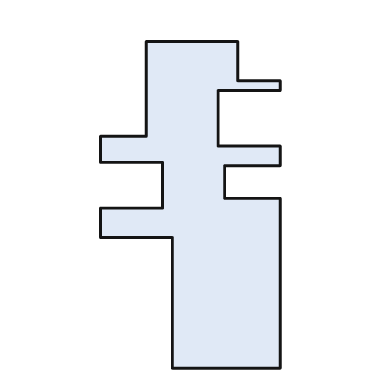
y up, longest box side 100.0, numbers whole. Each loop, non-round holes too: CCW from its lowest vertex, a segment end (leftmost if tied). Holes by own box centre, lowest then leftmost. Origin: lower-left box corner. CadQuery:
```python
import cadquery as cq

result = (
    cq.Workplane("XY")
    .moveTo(22.0, 0.0)
    .lineTo(55.0, 0.0)
    .lineTo(55.0, 52.0)
    .lineTo(38.0, 52.0)
    .lineTo(38.0, 62.0)
    .lineTo(55.0, 62.0)
    .lineTo(55.0, 68.0)
    .lineTo(36.0, 68.0)
    .lineTo(36.0, 85.0)
    .lineTo(55.0, 85.0)
    .lineTo(55.0, 88.0)
    .lineTo(42.0, 88.0)
    .lineTo(42.0, 100.0)
    .lineTo(14.0, 100.0)
    .lineTo(14.0, 71.0)
    .lineTo(0.0, 71.0)
    .lineTo(0.0, 63.0)
    .lineTo(19.0, 63.0)
    .lineTo(19.0, 49.0)
    .lineTo(0.0, 49.0)
    .lineTo(0.0, 40.0)
    .lineTo(22.0, 40.0)
    .close()
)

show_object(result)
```